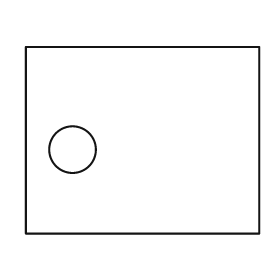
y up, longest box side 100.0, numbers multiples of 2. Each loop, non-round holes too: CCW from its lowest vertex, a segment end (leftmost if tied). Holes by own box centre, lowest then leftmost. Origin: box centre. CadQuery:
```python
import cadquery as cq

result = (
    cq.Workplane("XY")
    .moveTo(-50.0, -40.0)
    .lineTo(50.0, -40.0)
    .lineTo(50.0, 40.0)
    .lineTo(-50.0, 40.0)
    .close()
    .moveTo(-30.0, -4.0)
    .circle(10.0)
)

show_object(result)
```